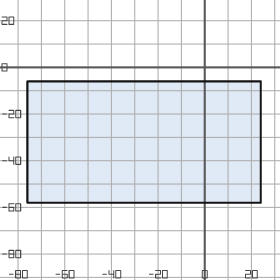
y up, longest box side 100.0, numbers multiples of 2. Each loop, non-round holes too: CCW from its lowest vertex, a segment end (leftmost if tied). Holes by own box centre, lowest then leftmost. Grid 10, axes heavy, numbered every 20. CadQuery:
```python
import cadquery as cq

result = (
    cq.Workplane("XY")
    .moveTo(-76.0, -58.0)
    .lineTo(24.0, -58.0)
    .lineTo(24.0, -6.0)
    .lineTo(-76.0, -6.0)
    .close()
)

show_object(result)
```